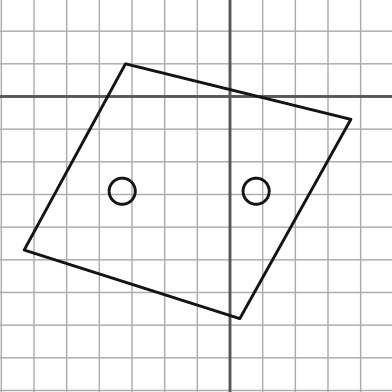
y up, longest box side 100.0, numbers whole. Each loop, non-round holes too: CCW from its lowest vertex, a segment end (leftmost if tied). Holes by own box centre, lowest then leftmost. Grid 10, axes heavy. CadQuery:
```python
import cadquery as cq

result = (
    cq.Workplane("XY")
    .moveTo(3.0, -68.0)
    .lineTo(37.0, -7.0)
    .lineTo(-32.0, 10.0)
    .lineTo(-63.0, -47.0)
    .close()
    .moveTo(-33.0, -29.0)
    .circle(4.0)
    .moveTo(8.0, -29.0)
    .circle(4.0)
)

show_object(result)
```